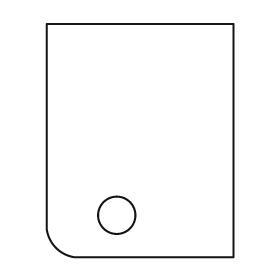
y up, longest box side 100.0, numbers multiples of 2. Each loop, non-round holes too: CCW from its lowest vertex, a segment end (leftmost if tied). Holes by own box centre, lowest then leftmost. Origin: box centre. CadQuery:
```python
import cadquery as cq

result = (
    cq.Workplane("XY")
    .moveTo(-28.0, -50.0)
    .lineTo(40.0, -50.0)
    .lineTo(40.0, 50.0)
    .lineTo(-40.0, 50.0)
    .lineTo(-40.0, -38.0)
    .threePointArc((-36.0, -46.0), (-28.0, -50.0))
    .close()
    .moveTo(-10.0, -32.0)
    .circle(8.0)
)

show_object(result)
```